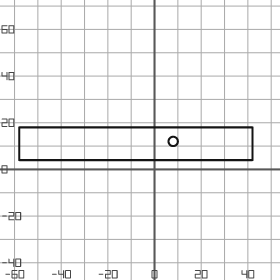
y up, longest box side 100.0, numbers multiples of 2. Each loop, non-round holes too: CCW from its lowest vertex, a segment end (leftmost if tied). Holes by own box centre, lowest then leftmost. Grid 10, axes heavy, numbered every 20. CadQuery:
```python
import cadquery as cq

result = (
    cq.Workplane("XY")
    .moveTo(-58.0, 4.0)
    .lineTo(42.0, 4.0)
    .lineTo(42.0, 18.0)
    .lineTo(-58.0, 18.0)
    .close()
    .moveTo(8.0, 12.0)
    .circle(2.0)
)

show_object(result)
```